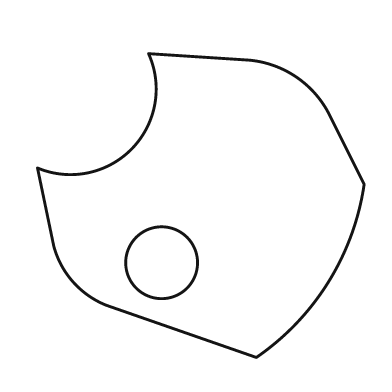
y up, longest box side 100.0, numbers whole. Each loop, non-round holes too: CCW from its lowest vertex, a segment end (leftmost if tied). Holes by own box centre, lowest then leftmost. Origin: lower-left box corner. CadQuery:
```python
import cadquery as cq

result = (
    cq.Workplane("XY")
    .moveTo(67.0, 0.0)
    .threePointArc((89.0, 23.0), (100.0, 53.0))
    .lineTo(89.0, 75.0)
    .threePointArc((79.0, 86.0), (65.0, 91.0))
    .lineTo(34.0, 93.0)
    .threePointArc((29.0, 64.0), (0.0, 58.0))
    .lineTo(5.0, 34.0)
    .threePointArc((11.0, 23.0), (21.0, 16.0))
    .close()
    .moveTo(38.0, 29.0)
    .circle(11.0)
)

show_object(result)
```